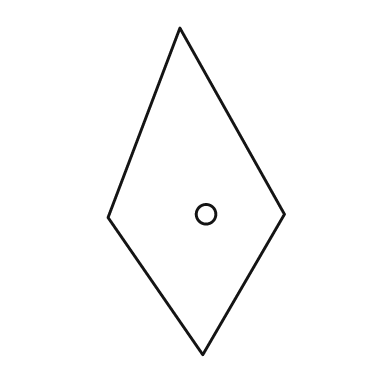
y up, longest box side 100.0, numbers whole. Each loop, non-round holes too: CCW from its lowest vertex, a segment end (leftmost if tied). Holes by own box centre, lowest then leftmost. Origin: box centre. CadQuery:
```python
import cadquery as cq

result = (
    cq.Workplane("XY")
    .moveTo(2.0, -50.0)
    .lineTo(27.0, -7.0)
    .lineTo(-5.0, 50.0)
    .lineTo(-27.0, -8.0)
    .close()
    .moveTo(3.0, -7.0)
    .circle(3.0)
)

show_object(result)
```